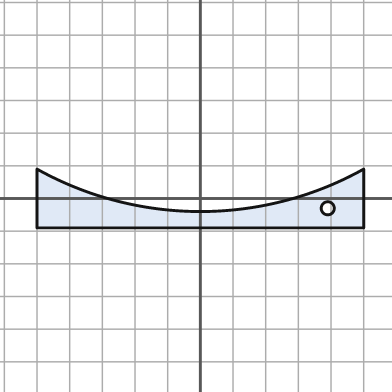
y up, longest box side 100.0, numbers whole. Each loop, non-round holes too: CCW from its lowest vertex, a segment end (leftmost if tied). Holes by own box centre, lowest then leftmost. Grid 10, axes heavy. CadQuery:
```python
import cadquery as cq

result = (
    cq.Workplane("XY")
    .moveTo(-50.0, -9.0)
    .lineTo(50.0, -9.0)
    .lineTo(50.0, 9.0)
    .threePointArc((0.0, -4.0), (-50.0, 9.0))
    .close()
    .moveTo(39.0, -3.0)
    .circle(2.0)
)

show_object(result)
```